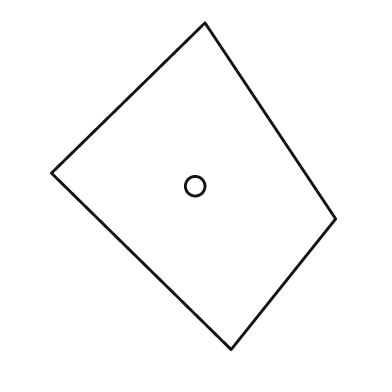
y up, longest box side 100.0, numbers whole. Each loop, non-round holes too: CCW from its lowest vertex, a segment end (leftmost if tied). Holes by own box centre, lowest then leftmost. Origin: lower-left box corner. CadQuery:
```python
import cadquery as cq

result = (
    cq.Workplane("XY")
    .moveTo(55.0, 0.0)
    .lineTo(87.0, 40.0)
    .lineTo(47.0, 100.0)
    .lineTo(0.0, 54.0)
    .close()
    .moveTo(44.0, 50.0)
    .circle(3.0)
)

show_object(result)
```